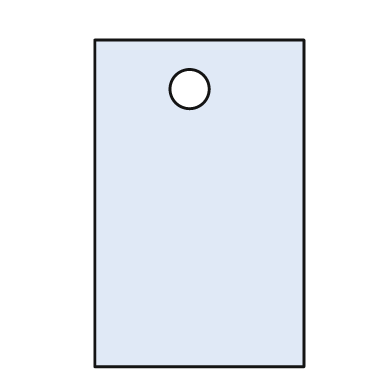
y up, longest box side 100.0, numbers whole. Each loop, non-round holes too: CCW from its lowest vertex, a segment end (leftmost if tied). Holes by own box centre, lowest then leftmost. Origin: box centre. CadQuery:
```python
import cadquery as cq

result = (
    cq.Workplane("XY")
    .moveTo(-32.0, -50.0)
    .lineTo(32.0, -50.0)
    .lineTo(32.0, 50.0)
    .lineTo(-32.0, 50.0)
    .close()
    .moveTo(-3.0, 35.0)
    .circle(6.0)
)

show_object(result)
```